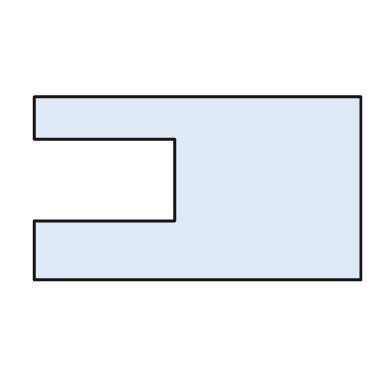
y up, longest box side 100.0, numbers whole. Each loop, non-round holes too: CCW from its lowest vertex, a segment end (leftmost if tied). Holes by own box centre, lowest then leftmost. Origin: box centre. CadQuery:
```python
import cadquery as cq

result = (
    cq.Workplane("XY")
    .moveTo(-50.0, -28.0)
    .lineTo(50.0, -28.0)
    .lineTo(50.0, 28.0)
    .lineTo(-50.0, 28.0)
    .lineTo(-50.0, 15.0)
    .lineTo(-7.0, 15.0)
    .lineTo(-7.0, -10.0)
    .lineTo(-50.0, -10.0)
    .close()
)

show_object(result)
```